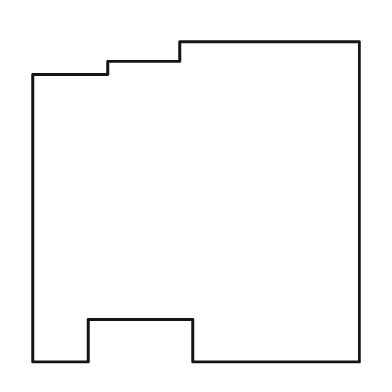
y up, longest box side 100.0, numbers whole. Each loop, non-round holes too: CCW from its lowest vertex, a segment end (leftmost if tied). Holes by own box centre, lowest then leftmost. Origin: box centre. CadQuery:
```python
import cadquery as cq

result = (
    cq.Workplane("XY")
    .moveTo(-50.0, -49.0)
    .lineTo(-33.0, -49.0)
    .lineTo(-33.0, -36.0)
    .lineTo(-1.0, -36.0)
    .lineTo(-1.0, -49.0)
    .lineTo(50.0, -49.0)
    .lineTo(50.0, 49.0)
    .lineTo(-5.0, 49.0)
    .lineTo(-5.0, 43.0)
    .lineTo(-27.0, 43.0)
    .lineTo(-27.0, 39.0)
    .lineTo(-50.0, 39.0)
    .close()
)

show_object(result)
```